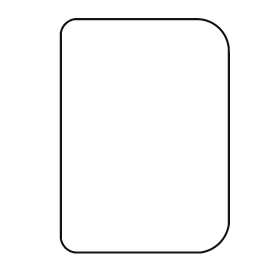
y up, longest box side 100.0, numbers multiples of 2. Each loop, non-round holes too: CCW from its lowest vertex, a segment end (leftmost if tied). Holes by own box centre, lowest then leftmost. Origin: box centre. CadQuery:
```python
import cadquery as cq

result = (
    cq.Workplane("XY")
    .moveTo(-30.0, -50.0)
    .lineTo(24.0, -50.0)
    .threePointArc((32.0, -46.0), (36.0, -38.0))
    .lineTo(36.0, 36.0)
    .threePointArc((32.0, 46.0), (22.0, 50.0))
    .lineTo(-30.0, 50.0)
    .threePointArc((-34.0, 48.0), (-36.0, 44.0))
    .lineTo(-36.0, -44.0)
    .threePointArc((-34.0, -48.0), (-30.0, -50.0))
    .close()
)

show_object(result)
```